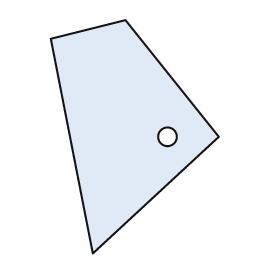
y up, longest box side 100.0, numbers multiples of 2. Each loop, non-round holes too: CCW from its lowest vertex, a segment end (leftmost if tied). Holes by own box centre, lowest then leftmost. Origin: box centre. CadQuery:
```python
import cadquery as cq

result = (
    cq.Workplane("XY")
    .moveTo(-18.0, -50.0)
    .lineTo(36.0, 0.0)
    .lineTo(-4.0, 50.0)
    .lineTo(-36.0, 42.0)
    .close()
    .moveTo(14.0, 0.0)
    .circle(4.0)
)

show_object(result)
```